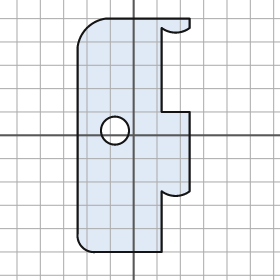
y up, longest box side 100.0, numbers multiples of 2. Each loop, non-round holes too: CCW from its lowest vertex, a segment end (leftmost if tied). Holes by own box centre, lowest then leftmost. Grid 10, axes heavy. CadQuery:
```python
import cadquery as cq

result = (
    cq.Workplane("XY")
    .moveTo(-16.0, -50.0)
    .lineTo(12.0, -50.0)
    .lineTo(12.0, -24.0)
    .threePointArc((18.0, -26.0), (24.0, -24.0))
    .lineTo(24.0, 10.0)
    .lineTo(12.0, 10.0)
    .lineTo(12.0, 46.0)
    .threePointArc((18.0, 44.0), (24.0, 46.0))
    .lineTo(24.0, 50.0)
    .lineTo(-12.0, 50.0)
    .threePointArc((-20.0, 46.0), (-24.0, 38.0))
    .lineTo(-24.0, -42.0)
    .threePointArc((-22.0, -48.0), (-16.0, -50.0))
    .close()
    .moveTo(-8.0, 2.0)
    .circle(6.0)
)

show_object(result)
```